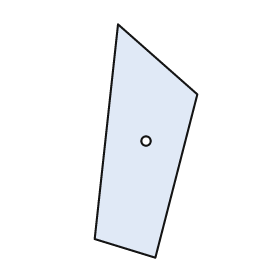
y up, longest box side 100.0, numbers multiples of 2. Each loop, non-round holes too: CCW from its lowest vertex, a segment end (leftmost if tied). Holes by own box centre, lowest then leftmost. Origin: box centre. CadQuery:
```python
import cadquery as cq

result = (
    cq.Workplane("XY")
    .moveTo(4.0, -50.0)
    .lineTo(22.0, 20.0)
    .lineTo(-12.0, 50.0)
    .lineTo(-22.0, -42.0)
    .close()
    .moveTo(0.0, 0.0)
    .circle(2.0)
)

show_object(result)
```